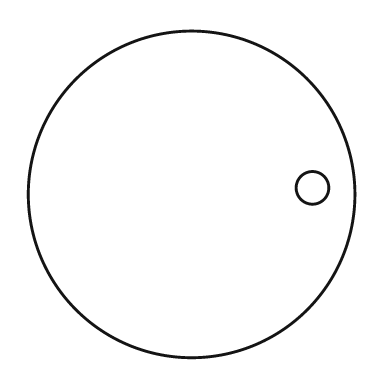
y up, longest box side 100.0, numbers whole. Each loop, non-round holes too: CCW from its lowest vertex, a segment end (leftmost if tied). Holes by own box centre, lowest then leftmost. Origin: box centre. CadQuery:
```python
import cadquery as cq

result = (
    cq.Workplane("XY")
    .moveTo(0.0, 0.0)
    .circle(50.0)
    .moveTo(37.0, 2.0)
    .circle(5.0)
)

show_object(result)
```